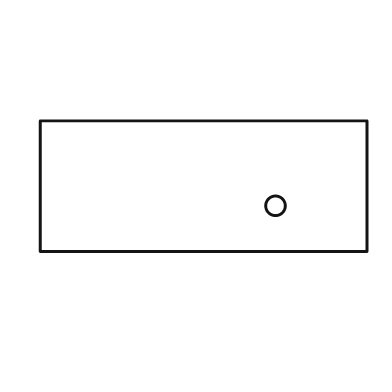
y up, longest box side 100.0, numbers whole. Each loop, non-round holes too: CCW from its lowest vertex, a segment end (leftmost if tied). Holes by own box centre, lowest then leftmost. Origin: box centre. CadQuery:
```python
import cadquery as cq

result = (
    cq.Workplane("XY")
    .moveTo(-50.0, -20.0)
    .lineTo(50.0, -20.0)
    .lineTo(50.0, 20.0)
    .lineTo(-50.0, 20.0)
    .close()
    .moveTo(22.0, -6.0)
    .circle(3.0)
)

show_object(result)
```